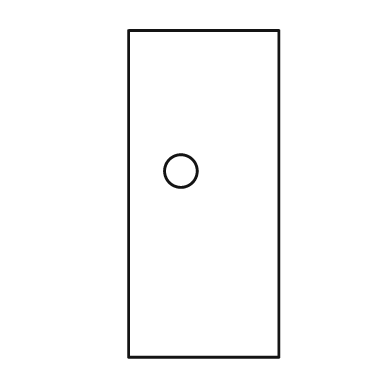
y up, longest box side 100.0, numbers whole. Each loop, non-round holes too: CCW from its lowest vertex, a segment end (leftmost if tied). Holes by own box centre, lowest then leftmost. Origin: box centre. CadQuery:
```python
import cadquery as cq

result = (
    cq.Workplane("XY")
    .moveTo(-23.0, -50.0)
    .lineTo(23.0, -50.0)
    .lineTo(23.0, 50.0)
    .lineTo(-23.0, 50.0)
    .close()
    .moveTo(-7.0, 7.0)
    .circle(5.0)
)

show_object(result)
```